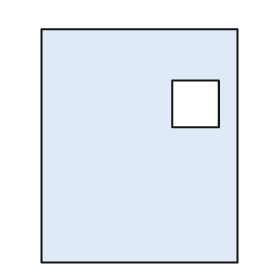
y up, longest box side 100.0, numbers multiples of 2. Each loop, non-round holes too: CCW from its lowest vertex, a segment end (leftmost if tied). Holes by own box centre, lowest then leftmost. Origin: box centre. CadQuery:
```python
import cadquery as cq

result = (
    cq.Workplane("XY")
    .moveTo(-42.0, -50.0)
    .lineTo(42.0, -50.0)
    .lineTo(42.0, 50.0)
    .lineTo(-42.0, 50.0)
    .close()
    .moveTo(14.0, 8.0)
    .lineTo(34.0, 8.0)
    .lineTo(34.0, 28.0)
    .lineTo(14.0, 28.0)
    .close()
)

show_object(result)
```